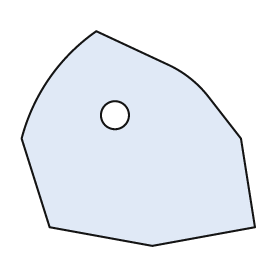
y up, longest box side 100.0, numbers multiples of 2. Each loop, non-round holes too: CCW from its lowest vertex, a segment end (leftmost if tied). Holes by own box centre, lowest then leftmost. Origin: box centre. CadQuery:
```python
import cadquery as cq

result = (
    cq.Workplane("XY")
    .moveTo(6.0, -46.0)
    .lineTo(50.0, -38.0)
    .lineTo(44.0, 0.0)
    .lineTo(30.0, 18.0)
    .threePointArc((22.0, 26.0), (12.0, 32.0))
    .lineTo(-18.0, 46.0)
    .threePointArc((-38.0, 26.0), (-50.0, 0.0))
    .lineTo(-38.0, -38.0)
    .close()
    .moveTo(-10.0, 10.0)
    .circle(6.0)
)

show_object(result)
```